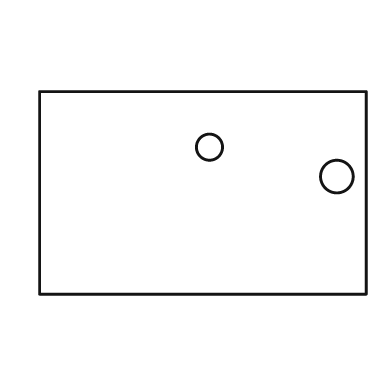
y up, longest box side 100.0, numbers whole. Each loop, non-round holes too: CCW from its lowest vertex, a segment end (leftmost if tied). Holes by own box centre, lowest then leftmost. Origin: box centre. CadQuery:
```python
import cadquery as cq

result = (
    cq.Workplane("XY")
    .moveTo(-50.0, -31.0)
    .lineTo(50.0, -31.0)
    .lineTo(50.0, 31.0)
    .lineTo(-50.0, 31.0)
    .close()
    .moveTo(41.0, 5.0)
    .circle(5.0)
    .moveTo(2.0, 14.0)
    .circle(4.0)
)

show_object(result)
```